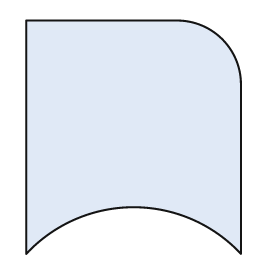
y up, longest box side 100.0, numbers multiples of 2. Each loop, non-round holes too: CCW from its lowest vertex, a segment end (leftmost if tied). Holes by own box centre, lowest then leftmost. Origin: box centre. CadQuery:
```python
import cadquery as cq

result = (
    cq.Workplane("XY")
    .moveTo(-46.0, -50.0)
    .threePointArc((0.0, -30.0), (46.0, -50.0))
    .lineTo(46.0, 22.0)
    .threePointArc((38.0, 42.0), (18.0, 50.0))
    .lineTo(-46.0, 50.0)
    .close()
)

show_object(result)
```